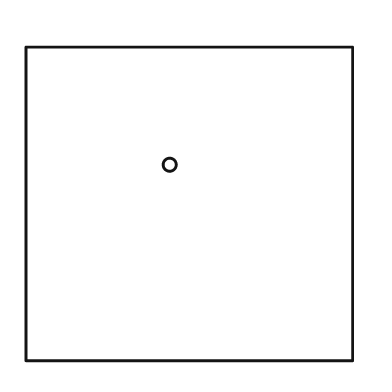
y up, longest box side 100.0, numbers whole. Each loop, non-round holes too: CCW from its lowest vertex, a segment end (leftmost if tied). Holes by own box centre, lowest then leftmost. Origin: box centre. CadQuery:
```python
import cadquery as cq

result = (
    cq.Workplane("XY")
    .moveTo(-50.0, -48.0)
    .lineTo(50.0, -48.0)
    .lineTo(50.0, 48.0)
    .lineTo(-50.0, 48.0)
    .close()
    .moveTo(-6.0, 12.0)
    .circle(2.0)
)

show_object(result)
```